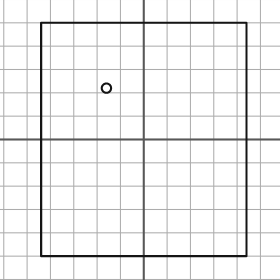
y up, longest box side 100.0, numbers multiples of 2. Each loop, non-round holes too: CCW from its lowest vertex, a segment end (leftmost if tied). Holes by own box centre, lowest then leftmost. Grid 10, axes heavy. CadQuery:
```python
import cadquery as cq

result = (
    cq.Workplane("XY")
    .moveTo(-44.0, -50.0)
    .lineTo(44.0, -50.0)
    .lineTo(44.0, 50.0)
    .lineTo(-44.0, 50.0)
    .close()
    .moveTo(-16.0, 22.0)
    .circle(2.0)
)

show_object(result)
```